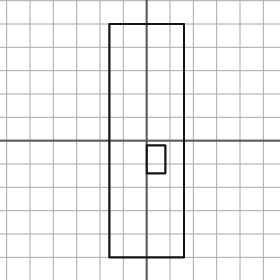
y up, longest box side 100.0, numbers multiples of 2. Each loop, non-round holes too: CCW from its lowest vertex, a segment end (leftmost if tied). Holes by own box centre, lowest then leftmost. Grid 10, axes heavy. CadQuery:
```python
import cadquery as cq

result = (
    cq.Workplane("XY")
    .moveTo(-16.0, -50.0)
    .lineTo(16.0, -50.0)
    .lineTo(16.0, 50.0)
    .lineTo(-16.0, 50.0)
    .close()
    .moveTo(0.0, -14.0)
    .lineTo(8.0, -14.0)
    .lineTo(8.0, -2.0)
    .lineTo(0.0, -2.0)
    .close()
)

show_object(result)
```